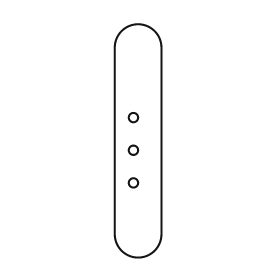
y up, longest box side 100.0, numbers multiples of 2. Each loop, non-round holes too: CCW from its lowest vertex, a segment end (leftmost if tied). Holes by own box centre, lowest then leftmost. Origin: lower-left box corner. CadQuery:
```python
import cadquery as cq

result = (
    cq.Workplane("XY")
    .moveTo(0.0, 10.0)
    .threePointArc((10.0, 0.0), (20.0, 10.0))
    .lineTo(20.0, 90.0)
    .threePointArc((10.0, 100.0), (0.0, 90.0))
    .close()
    .moveTo(8.0, 32.0)
    .circle(2.0)
    .moveTo(8.0, 46.0)
    .circle(2.0)
    .moveTo(8.0, 60.0)
    .circle(2.0)
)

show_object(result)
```